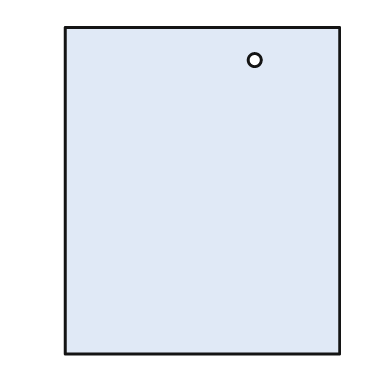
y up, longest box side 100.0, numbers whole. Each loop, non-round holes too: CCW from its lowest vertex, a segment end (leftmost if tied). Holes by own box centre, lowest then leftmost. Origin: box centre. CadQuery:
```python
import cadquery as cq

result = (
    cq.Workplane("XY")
    .moveTo(-42.0, -50.0)
    .lineTo(42.0, -50.0)
    .lineTo(42.0, 50.0)
    .lineTo(-42.0, 50.0)
    .close()
    .moveTo(16.0, 40.0)
    .circle(2.0)
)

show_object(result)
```